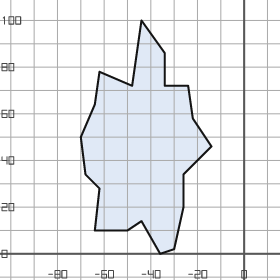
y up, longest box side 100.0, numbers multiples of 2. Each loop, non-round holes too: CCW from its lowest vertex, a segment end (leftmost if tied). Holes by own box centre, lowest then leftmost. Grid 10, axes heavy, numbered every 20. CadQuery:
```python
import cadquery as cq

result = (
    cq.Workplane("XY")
    .moveTo(-36.0, 0.0)
    .lineTo(-30.0, 2.0)
    .lineTo(-26.0, 20.0)
    .lineTo(-26.0, 34.0)
    .lineTo(-14.0, 46.0)
    .lineTo(-22.0, 58.0)
    .lineTo(-24.0, 72.0)
    .lineTo(-34.0, 72.0)
    .lineTo(-34.0, 86.0)
    .lineTo(-44.0, 100.0)
    .lineTo(-48.0, 72.0)
    .lineTo(-62.0, 78.0)
    .lineTo(-64.0, 64.0)
    .lineTo(-70.0, 50.0)
    .lineTo(-68.0, 34.0)
    .lineTo(-62.0, 28.0)
    .lineTo(-64.0, 10.0)
    .lineTo(-50.0, 10.0)
    .lineTo(-44.0, 14.0)
    .close()
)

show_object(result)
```